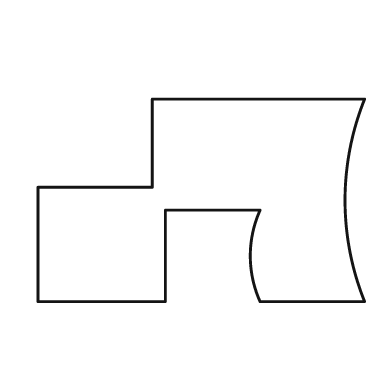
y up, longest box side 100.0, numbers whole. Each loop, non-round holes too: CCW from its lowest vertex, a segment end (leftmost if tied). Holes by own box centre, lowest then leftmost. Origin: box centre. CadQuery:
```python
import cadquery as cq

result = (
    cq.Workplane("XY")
    .moveTo(-50.0, -31.0)
    .lineTo(-11.0, -31.0)
    .lineTo(-11.0, -3.0)
    .lineTo(18.0, -3.0)
    .threePointArc((15.0, -17.0), (18.0, -31.0))
    .lineTo(50.0, -31.0)
    .threePointArc((44.0, 0.0), (50.0, 31.0))
    .lineTo(-15.0, 31.0)
    .lineTo(-15.0, 4.0)
    .lineTo(-50.0, 4.0)
    .close()
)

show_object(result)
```